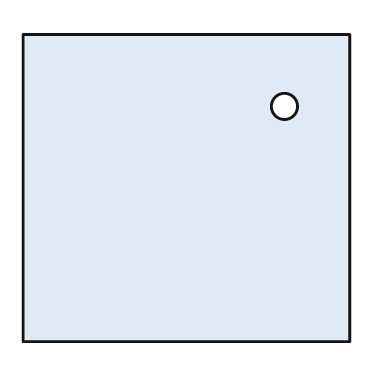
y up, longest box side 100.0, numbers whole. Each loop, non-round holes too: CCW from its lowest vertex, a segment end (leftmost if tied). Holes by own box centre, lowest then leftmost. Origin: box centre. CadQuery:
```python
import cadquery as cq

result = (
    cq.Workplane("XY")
    .moveTo(-50.0, -47.0)
    .lineTo(50.0, -47.0)
    .lineTo(50.0, 47.0)
    .lineTo(-50.0, 47.0)
    .close()
    .moveTo(30.0, 25.0)
    .circle(4.0)
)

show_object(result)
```